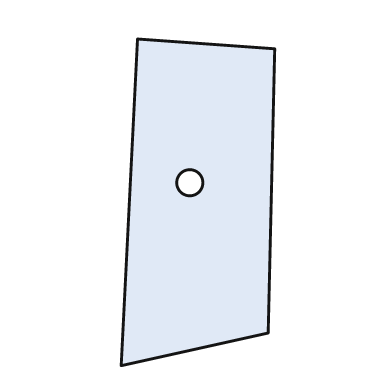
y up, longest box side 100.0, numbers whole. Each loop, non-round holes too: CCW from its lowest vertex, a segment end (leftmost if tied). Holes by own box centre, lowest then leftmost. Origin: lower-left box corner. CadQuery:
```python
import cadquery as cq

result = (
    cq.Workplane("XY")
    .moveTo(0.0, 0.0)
    .lineTo(45.0, 10.0)
    .lineTo(47.0, 97.0)
    .lineTo(5.0, 100.0)
    .close()
    .moveTo(21.0, 56.0)
    .circle(4.0)
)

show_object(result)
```